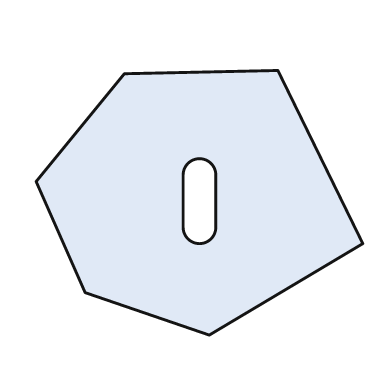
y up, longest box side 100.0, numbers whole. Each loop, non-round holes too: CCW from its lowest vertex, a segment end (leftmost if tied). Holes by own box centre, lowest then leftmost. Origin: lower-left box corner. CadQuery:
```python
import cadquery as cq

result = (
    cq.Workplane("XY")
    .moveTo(53.0, 0.0)
    .lineTo(100.0, 28.0)
    .lineTo(74.0, 81.0)
    .lineTo(27.0, 80.0)
    .lineTo(0.0, 47.0)
    .lineTo(15.0, 13.0)
    .close()
    .moveTo(45.0, 33.0)
    .threePointArc((50.0, 28.0), (55.0, 33.0))
    .lineTo(55.0, 49.0)
    .threePointArc((50.0, 54.0), (45.0, 49.0))
    .close()
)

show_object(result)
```